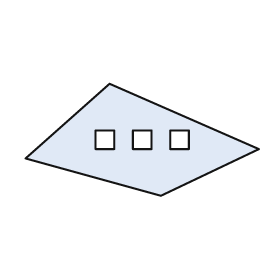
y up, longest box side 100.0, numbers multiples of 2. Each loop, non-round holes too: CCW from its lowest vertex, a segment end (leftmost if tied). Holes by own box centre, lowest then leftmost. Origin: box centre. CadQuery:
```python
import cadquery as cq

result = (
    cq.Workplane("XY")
    .moveTo(8.0, -24.0)
    .lineTo(50.0, -4.0)
    .lineTo(-14.0, 24.0)
    .lineTo(-50.0, -8.0)
    .close()
    .moveTo(-20.0, -4.0)
    .lineTo(-12.0, -4.0)
    .lineTo(-12.0, 4.0)
    .lineTo(-20.0, 4.0)
    .close()
    .moveTo(-4.0, -4.0)
    .lineTo(4.0, -4.0)
    .lineTo(4.0, 4.0)
    .lineTo(-4.0, 4.0)
    .close()
    .moveTo(12.0, -4.0)
    .lineTo(20.0, -4.0)
    .lineTo(20.0, 4.0)
    .lineTo(12.0, 4.0)
    .close()
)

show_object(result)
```